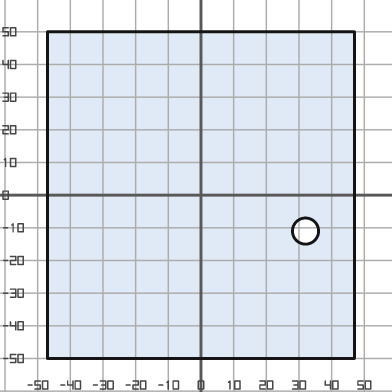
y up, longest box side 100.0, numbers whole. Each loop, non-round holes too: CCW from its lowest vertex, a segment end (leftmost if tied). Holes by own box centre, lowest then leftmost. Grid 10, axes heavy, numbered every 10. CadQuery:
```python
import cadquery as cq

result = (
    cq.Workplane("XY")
    .moveTo(-47.0, -50.0)
    .lineTo(47.0, -50.0)
    .lineTo(47.0, 50.0)
    .lineTo(-47.0, 50.0)
    .close()
    .moveTo(32.0, -11.0)
    .circle(4.0)
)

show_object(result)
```